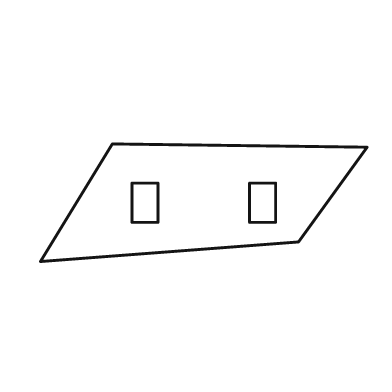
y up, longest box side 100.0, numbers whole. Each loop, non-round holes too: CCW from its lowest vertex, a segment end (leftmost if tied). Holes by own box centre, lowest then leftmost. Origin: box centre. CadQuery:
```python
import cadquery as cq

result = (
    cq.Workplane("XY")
    .moveTo(-50.0, -18.0)
    .lineTo(29.0, -12.0)
    .lineTo(50.0, 17.0)
    .lineTo(-28.0, 18.0)
    .close()
    .moveTo(-22.0, -6.0)
    .lineTo(-14.0, -6.0)
    .lineTo(-14.0, 6.0)
    .lineTo(-22.0, 6.0)
    .close()
    .moveTo(14.0, -6.0)
    .lineTo(22.0, -6.0)
    .lineTo(22.0, 6.0)
    .lineTo(14.0, 6.0)
    .close()
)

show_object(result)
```